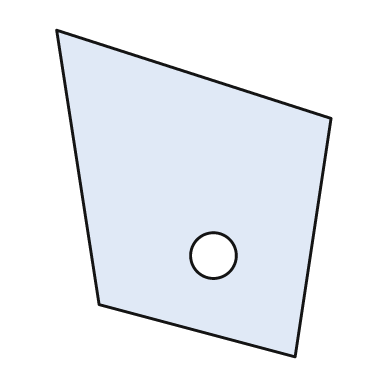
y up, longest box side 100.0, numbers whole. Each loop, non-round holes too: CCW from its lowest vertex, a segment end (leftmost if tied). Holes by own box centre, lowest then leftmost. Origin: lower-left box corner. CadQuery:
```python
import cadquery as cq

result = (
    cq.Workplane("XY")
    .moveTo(73.0, 0.0)
    .lineTo(84.0, 73.0)
    .lineTo(0.0, 100.0)
    .lineTo(13.0, 16.0)
    .close()
    .moveTo(48.0, 31.0)
    .circle(7.0)
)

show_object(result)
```